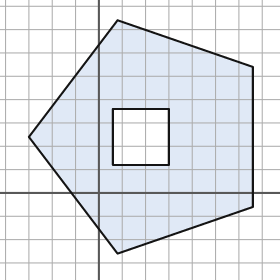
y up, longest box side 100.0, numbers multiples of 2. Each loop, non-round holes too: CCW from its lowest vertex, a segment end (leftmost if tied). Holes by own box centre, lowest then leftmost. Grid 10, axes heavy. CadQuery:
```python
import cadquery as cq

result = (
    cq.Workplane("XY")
    .moveTo(8.0, -26.0)
    .lineTo(66.0, -6.0)
    .lineTo(66.0, 54.0)
    .lineTo(8.0, 74.0)
    .lineTo(-30.0, 24.0)
    .close()
    .moveTo(6.0, 12.0)
    .lineTo(30.0, 12.0)
    .lineTo(30.0, 36.0)
    .lineTo(6.0, 36.0)
    .close()
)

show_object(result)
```